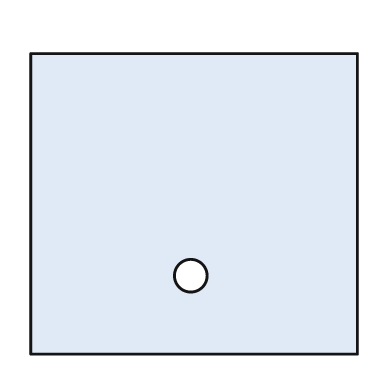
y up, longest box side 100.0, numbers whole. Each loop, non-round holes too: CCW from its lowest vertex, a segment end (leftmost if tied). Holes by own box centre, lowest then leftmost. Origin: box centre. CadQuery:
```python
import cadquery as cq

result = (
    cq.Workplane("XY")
    .moveTo(-50.0, -46.0)
    .lineTo(50.0, -46.0)
    .lineTo(50.0, 46.0)
    .lineTo(-50.0, 46.0)
    .close()
    .moveTo(-1.0, -22.0)
    .circle(5.0)
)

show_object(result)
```